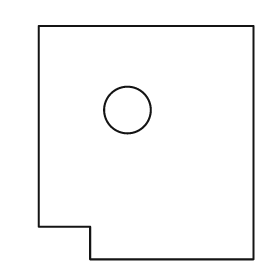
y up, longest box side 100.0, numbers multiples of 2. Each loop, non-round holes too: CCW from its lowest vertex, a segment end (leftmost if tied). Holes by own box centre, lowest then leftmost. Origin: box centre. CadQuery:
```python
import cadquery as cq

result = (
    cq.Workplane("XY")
    .moveTo(-24.0, -50.0)
    .lineTo(46.0, -50.0)
    .lineTo(46.0, 50.0)
    .lineTo(-46.0, 50.0)
    .lineTo(-46.0, -36.0)
    .lineTo(-24.0, -36.0)
    .close()
    .moveTo(-8.0, 14.0)
    .circle(10.0)
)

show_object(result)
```